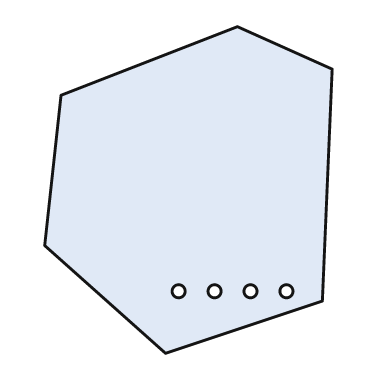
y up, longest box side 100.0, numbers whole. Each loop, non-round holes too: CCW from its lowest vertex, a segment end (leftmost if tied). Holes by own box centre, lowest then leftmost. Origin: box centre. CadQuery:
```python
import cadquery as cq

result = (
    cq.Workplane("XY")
    .moveTo(-7.0, -50.0)
    .lineTo(41.0, -34.0)
    .lineTo(44.0, 37.0)
    .lineTo(15.0, 50.0)
    .lineTo(-39.0, 29.0)
    .lineTo(-44.0, -17.0)
    .close()
    .moveTo(-3.0, -31.0)
    .circle(2.0)
    .moveTo(8.0, -31.0)
    .circle(2.0)
    .moveTo(19.0, -31.0)
    .circle(2.0)
    .moveTo(30.0, -31.0)
    .circle(2.0)
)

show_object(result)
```